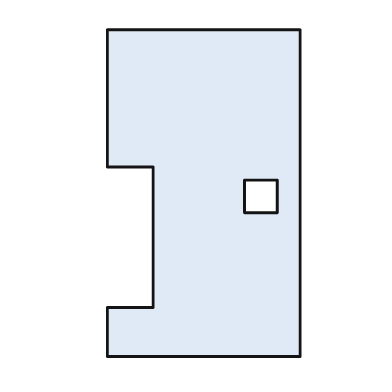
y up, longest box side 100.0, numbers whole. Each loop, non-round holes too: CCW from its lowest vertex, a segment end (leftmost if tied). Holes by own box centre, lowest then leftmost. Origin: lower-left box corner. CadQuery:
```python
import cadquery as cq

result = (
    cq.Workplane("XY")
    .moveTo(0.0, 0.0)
    .lineTo(59.0, 0.0)
    .lineTo(59.0, 100.0)
    .lineTo(0.0, 100.0)
    .lineTo(0.0, 58.0)
    .lineTo(14.0, 58.0)
    .lineTo(14.0, 15.0)
    .lineTo(0.0, 15.0)
    .close()
    .moveTo(42.0, 44.0)
    .lineTo(52.0, 44.0)
    .lineTo(52.0, 54.0)
    .lineTo(42.0, 54.0)
    .close()
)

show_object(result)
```